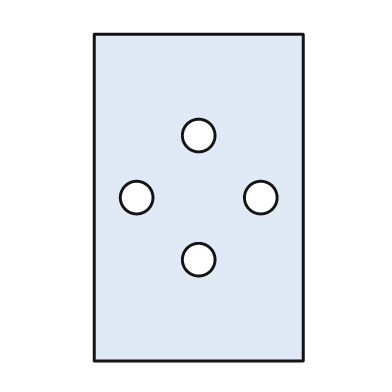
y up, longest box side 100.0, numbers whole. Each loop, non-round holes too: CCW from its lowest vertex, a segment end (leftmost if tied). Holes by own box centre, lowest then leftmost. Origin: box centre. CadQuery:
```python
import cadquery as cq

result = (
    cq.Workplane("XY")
    .moveTo(-32.0, -50.0)
    .lineTo(32.0, -50.0)
    .lineTo(32.0, 50.0)
    .lineTo(-32.0, 50.0)
    .close()
    .moveTo(0.0, -19.0)
    .circle(5.0)
    .moveTo(-19.0, 0.0)
    .circle(5.0)
    .moveTo(19.0, 0.0)
    .circle(5.0)
    .moveTo(0.0, 19.0)
    .circle(5.0)
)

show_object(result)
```